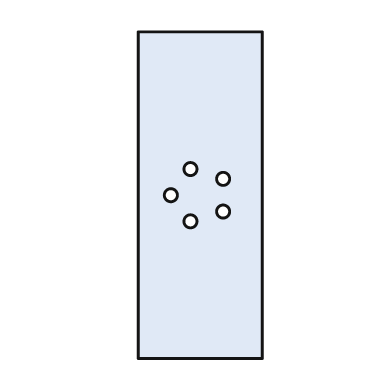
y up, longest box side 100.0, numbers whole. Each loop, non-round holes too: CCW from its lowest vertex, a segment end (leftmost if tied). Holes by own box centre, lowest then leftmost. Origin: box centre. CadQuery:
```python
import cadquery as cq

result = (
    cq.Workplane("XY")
    .moveTo(-19.0, -50.0)
    .lineTo(19.0, -50.0)
    .lineTo(19.0, 50.0)
    .lineTo(-19.0, 50.0)
    .close()
    .moveTo(-3.0, -8.0)
    .circle(2.0)
    .moveTo(7.0, -5.0)
    .circle(2.0)
    .moveTo(-9.0, 0.0)
    .circle(2.0)
    .moveTo(7.0, 5.0)
    .circle(2.0)
    .moveTo(-3.0, 8.0)
    .circle(2.0)
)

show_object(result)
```